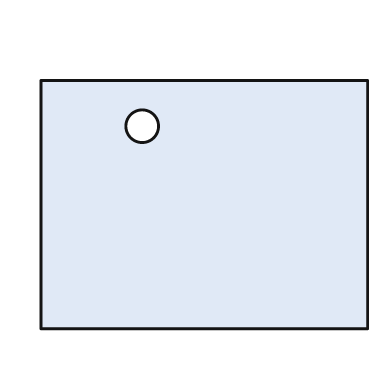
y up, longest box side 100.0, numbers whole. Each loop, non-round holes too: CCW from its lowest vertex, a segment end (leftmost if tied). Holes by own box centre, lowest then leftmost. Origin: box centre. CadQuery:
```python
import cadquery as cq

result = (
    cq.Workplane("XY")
    .moveTo(-50.0, -38.0)
    .lineTo(50.0, -38.0)
    .lineTo(50.0, 38.0)
    .lineTo(-50.0, 38.0)
    .close()
    .moveTo(-19.0, 24.0)
    .circle(5.0)
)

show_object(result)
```